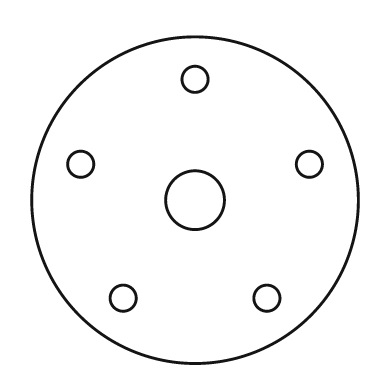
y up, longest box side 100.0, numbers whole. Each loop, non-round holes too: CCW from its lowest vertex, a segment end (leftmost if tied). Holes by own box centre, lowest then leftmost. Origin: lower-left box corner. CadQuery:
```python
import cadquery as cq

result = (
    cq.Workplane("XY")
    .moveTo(50.0, 50.0)
    .circle(50.0)
    .moveTo(28.0, 20.0)
    .circle(4.0)
    .moveTo(72.0, 20.0)
    .circle(4.0)
    .moveTo(50.0, 50.0)
    .circle(9.0)
    .moveTo(15.0, 61.0)
    .circle(4.0)
    .moveTo(85.0, 61.0)
    .circle(4.0)
    .moveTo(50.0, 87.0)
    .circle(4.0)
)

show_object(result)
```